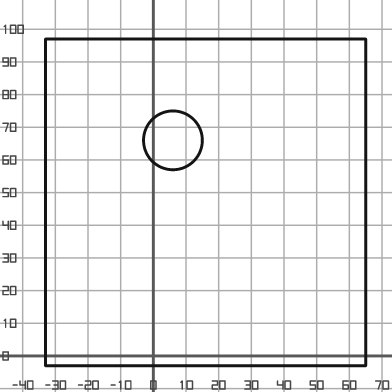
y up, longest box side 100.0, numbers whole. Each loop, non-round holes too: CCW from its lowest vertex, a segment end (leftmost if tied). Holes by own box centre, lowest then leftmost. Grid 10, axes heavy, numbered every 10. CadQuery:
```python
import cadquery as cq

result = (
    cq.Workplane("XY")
    .moveTo(-33.0, -3.0)
    .lineTo(65.0, -3.0)
    .lineTo(65.0, 97.0)
    .lineTo(-33.0, 97.0)
    .close()
    .moveTo(6.0, 66.0)
    .circle(9.0)
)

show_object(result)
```